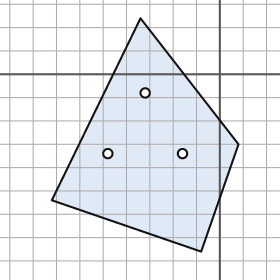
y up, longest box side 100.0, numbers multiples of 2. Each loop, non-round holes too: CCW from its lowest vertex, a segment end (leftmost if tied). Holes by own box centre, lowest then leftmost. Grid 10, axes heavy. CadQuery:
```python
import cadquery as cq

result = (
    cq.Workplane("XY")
    .moveTo(-8.0, -76.0)
    .lineTo(8.0, -30.0)
    .lineTo(-34.0, 24.0)
    .lineTo(-72.0, -54.0)
    .close()
    .moveTo(-48.0, -34.0)
    .circle(2.0)
    .moveTo(-16.0, -34.0)
    .circle(2.0)
    .moveTo(-32.0, -8.0)
    .circle(2.0)
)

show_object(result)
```